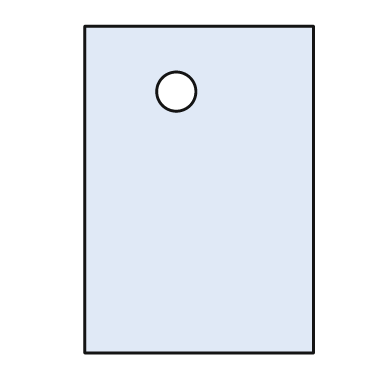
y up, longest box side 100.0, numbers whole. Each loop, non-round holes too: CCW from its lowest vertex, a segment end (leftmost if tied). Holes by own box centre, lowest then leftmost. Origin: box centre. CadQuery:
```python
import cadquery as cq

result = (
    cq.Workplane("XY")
    .moveTo(-35.0, -50.0)
    .lineTo(35.0, -50.0)
    .lineTo(35.0, 50.0)
    .lineTo(-35.0, 50.0)
    .close()
    .moveTo(-7.0, 30.0)
    .circle(6.0)
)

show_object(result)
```